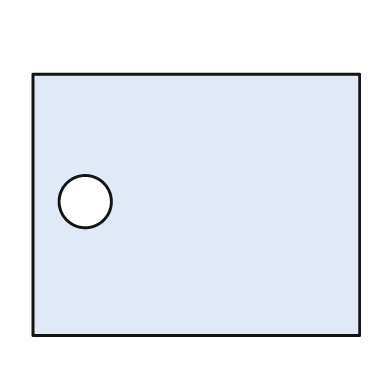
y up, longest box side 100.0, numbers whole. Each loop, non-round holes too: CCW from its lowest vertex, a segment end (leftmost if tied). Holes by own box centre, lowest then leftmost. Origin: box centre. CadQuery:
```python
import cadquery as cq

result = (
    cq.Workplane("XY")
    .moveTo(-50.0, -40.0)
    .lineTo(50.0, -40.0)
    .lineTo(50.0, 40.0)
    .lineTo(-50.0, 40.0)
    .close()
    .moveTo(-34.0, 1.0)
    .circle(8.0)
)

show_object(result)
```